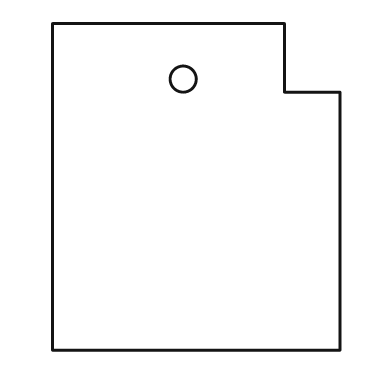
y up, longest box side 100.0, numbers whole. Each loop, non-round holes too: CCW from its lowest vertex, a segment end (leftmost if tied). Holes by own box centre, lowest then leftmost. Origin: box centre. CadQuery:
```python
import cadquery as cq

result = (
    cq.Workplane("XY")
    .moveTo(-44.0, -50.0)
    .lineTo(44.0, -50.0)
    .lineTo(44.0, 29.0)
    .lineTo(27.0, 29.0)
    .lineTo(27.0, 50.0)
    .lineTo(-44.0, 50.0)
    .close()
    .moveTo(-4.0, 33.0)
    .circle(4.0)
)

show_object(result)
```